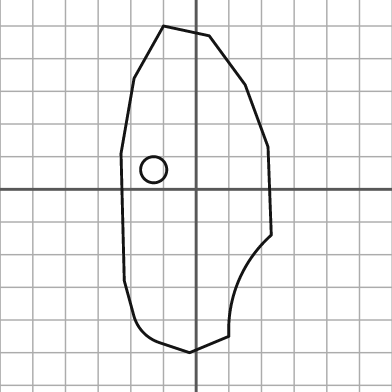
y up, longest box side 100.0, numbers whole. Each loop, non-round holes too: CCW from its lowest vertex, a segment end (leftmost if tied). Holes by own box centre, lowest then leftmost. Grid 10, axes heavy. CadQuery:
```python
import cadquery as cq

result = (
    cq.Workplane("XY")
    .moveTo(-2.0, -50.0)
    .lineTo(10.0, -45.0)
    .threePointArc((13.0, -28.0), (23.0, -14.0))
    .lineTo(22.0, 13.0)
    .lineTo(15.0, 32.0)
    .lineTo(4.0, 47.0)
    .lineTo(-10.0, 50.0)
    .lineTo(-19.0, 34.0)
    .lineTo(-23.0, 11.0)
    .lineTo(-22.0, -28.0)
    .lineTo(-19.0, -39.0)
    .threePointArc((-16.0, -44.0), (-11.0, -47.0))
    .close()
    .moveTo(-13.0, 6.0)
    .circle(4.0)
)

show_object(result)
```